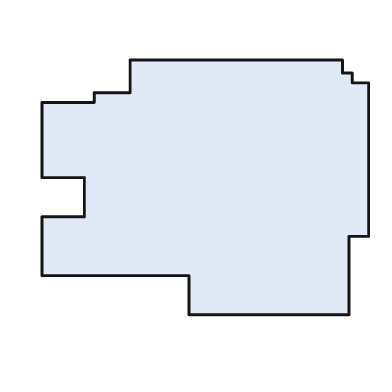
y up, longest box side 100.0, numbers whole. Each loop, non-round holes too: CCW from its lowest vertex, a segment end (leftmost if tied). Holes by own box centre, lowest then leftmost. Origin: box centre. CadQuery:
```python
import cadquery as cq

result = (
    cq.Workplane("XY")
    .moveTo(-5.0, -39.0)
    .lineTo(44.0, -39.0)
    .lineTo(44.0, -15.0)
    .lineTo(50.0, -15.0)
    .lineTo(50.0, 32.0)
    .lineTo(45.0, 32.0)
    .lineTo(45.0, 35.0)
    .lineTo(42.0, 35.0)
    .lineTo(42.0, 39.0)
    .lineTo(-23.0, 39.0)
    .lineTo(-23.0, 29.0)
    .lineTo(-34.0, 29.0)
    .lineTo(-34.0, 26.0)
    .lineTo(-50.0, 26.0)
    .lineTo(-50.0, 3.0)
    .lineTo(-37.0, 3.0)
    .lineTo(-37.0, -9.0)
    .lineTo(-50.0, -9.0)
    .lineTo(-50.0, -27.0)
    .lineTo(-5.0, -27.0)
    .close()
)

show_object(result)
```